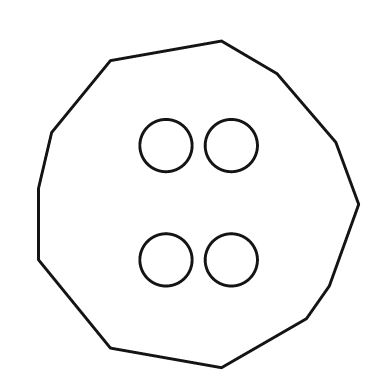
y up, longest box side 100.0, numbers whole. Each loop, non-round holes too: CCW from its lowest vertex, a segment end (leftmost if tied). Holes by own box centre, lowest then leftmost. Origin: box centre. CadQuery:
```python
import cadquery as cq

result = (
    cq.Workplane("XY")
    .moveTo(7.0, -50.0)
    .lineTo(33.0, -35.0)
    .lineTo(40.0, -25.0)
    .lineTo(49.0, 0.0)
    .lineTo(42.0, 19.0)
    .lineTo(24.0, 40.0)
    .lineTo(7.0, 50.0)
    .lineTo(-27.0, 44.0)
    .lineTo(-45.0, 22.0)
    .lineTo(-49.0, 5.0)
    .lineTo(-49.0, -17.0)
    .lineTo(-27.0, -44.0)
    .close()
    .moveTo(-10.0, -17.0)
    .circle(8.0)
    .moveTo(10.0, -17.0)
    .circle(8.0)
    .moveTo(-10.0, 18.0)
    .circle(8.0)
    .moveTo(10.0, 18.0)
    .circle(8.0)
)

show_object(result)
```